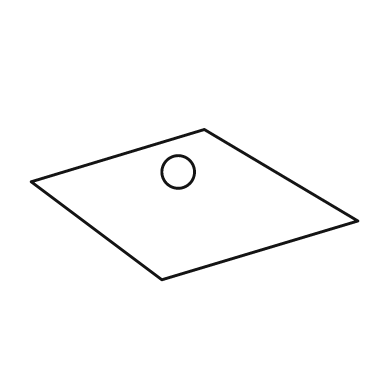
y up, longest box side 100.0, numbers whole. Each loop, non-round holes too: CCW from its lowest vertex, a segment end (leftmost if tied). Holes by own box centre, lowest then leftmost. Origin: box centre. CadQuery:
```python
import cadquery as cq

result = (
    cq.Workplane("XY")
    .moveTo(-10.0, -23.0)
    .lineTo(50.0, -5.0)
    .lineTo(3.0, 23.0)
    .lineTo(-50.0, 7.0)
    .close()
    .moveTo(-5.0, 10.0)
    .circle(5.0)
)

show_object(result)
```